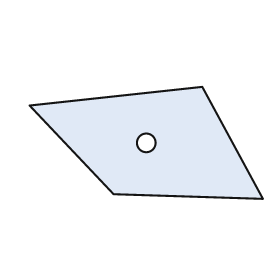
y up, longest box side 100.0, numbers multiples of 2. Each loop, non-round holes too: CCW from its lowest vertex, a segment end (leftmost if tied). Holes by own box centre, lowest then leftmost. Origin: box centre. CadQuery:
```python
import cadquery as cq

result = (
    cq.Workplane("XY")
    .moveTo(50.0, -24.0)
    .lineTo(24.0, 24.0)
    .lineTo(-50.0, 16.0)
    .lineTo(-14.0, -22.0)
    .close()
    .moveTo(0.0, 0.0)
    .circle(4.0)
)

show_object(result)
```